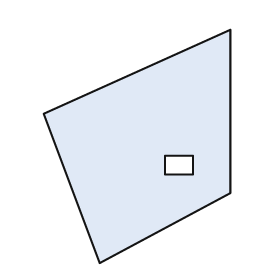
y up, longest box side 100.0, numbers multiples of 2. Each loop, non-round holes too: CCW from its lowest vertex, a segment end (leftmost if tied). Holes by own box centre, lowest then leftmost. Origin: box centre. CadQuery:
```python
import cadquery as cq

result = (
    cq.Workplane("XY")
    .moveTo(-16.0, -50.0)
    .lineTo(40.0, -20.0)
    .lineTo(40.0, 50.0)
    .lineTo(-40.0, 14.0)
    .close()
    .moveTo(12.0, -12.0)
    .lineTo(24.0, -12.0)
    .lineTo(24.0, -4.0)
    .lineTo(12.0, -4.0)
    .close()
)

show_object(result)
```